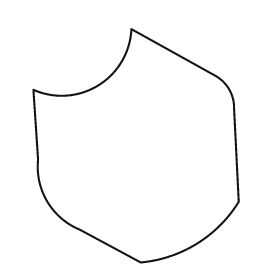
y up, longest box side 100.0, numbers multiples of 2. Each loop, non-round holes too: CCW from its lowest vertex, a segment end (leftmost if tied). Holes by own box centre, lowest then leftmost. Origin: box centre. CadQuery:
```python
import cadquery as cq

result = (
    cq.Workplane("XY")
    .moveTo(2.0, -50.0)
    .threePointArc((26.0, -42.0), (44.0, -24.0))
    .lineTo(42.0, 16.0)
    .threePointArc((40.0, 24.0), (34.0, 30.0))
    .lineTo(-2.0, 50.0)
    .threePointArc((-16.0, 26.0), (-44.0, 24.0))
    .lineTo(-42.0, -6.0)
    .threePointArc((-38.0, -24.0), (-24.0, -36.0))
    .close()
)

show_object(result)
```